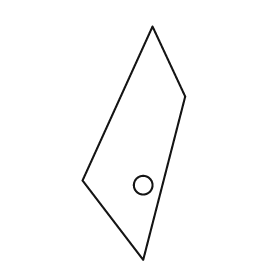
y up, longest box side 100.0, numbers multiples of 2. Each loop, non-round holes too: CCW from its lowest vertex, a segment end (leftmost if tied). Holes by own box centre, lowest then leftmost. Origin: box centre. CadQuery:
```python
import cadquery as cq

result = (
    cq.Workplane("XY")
    .moveTo(4.0, -50.0)
    .lineTo(22.0, 20.0)
    .lineTo(8.0, 50.0)
    .lineTo(-22.0, -16.0)
    .close()
    .moveTo(4.0, -18.0)
    .circle(4.0)
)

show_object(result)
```